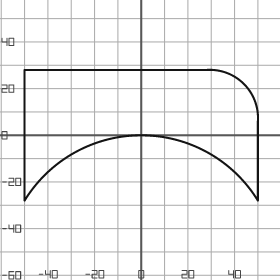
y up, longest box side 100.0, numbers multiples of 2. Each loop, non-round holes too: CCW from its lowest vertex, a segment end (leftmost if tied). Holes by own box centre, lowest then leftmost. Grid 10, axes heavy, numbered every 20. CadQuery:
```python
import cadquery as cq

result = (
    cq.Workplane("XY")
    .moveTo(-50.0, -28.0)
    .threePointArc((0.0, 0.0), (50.0, -28.0))
    .lineTo(50.0, 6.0)
    .threePointArc((44.0, 22.0), (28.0, 28.0))
    .lineTo(-50.0, 28.0)
    .close()
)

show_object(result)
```